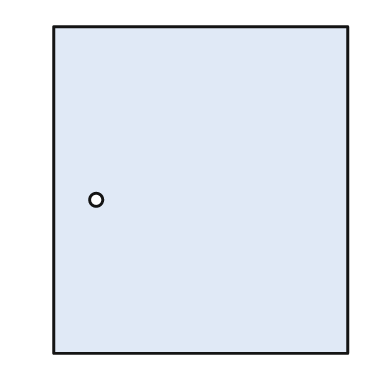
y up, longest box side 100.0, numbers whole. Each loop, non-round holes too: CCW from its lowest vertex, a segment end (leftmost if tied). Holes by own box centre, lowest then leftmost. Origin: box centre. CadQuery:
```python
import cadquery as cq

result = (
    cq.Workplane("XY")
    .moveTo(-45.0, -50.0)
    .lineTo(45.0, -50.0)
    .lineTo(45.0, 50.0)
    .lineTo(-45.0, 50.0)
    .close()
    .moveTo(-32.0, -3.0)
    .circle(2.0)
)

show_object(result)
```